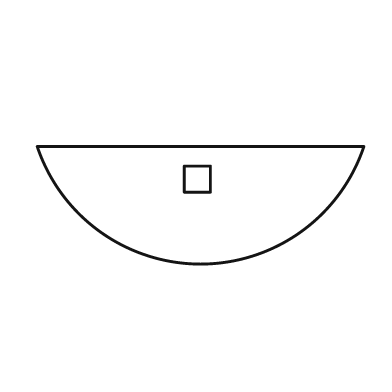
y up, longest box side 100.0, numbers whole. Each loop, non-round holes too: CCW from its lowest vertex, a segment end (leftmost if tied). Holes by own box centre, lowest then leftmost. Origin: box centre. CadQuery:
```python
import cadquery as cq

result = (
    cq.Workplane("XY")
    .moveTo(-50.0, 18.0)
    .threePointArc((0.0, -18.0), (50.0, 18.0))
    .close()
    .moveTo(-5.0, 4.0)
    .lineTo(3.0, 4.0)
    .lineTo(3.0, 12.0)
    .lineTo(-5.0, 12.0)
    .close()
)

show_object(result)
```